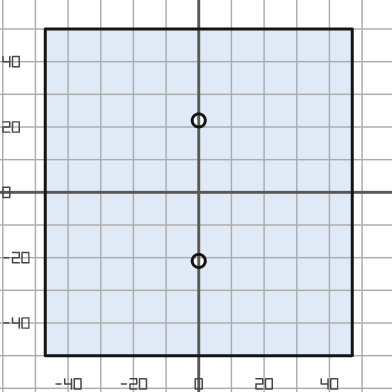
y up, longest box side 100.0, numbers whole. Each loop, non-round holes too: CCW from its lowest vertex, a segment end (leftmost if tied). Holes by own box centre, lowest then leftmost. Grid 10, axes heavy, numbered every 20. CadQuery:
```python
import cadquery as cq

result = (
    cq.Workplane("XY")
    .moveTo(-47.0, -50.0)
    .lineTo(47.0, -50.0)
    .lineTo(47.0, 50.0)
    .lineTo(-47.0, 50.0)
    .close()
    .moveTo(0.0, -21.0)
    .circle(2.0)
    .moveTo(0.0, 22.0)
    .circle(2.0)
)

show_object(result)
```